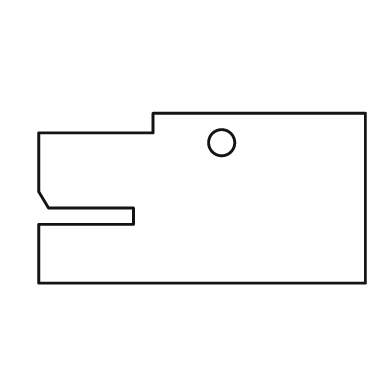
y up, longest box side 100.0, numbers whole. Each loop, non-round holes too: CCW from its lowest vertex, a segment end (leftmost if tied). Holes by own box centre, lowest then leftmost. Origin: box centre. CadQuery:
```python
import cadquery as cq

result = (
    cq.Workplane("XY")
    .moveTo(-50.0, -26.0)
    .lineTo(50.0, -26.0)
    .lineTo(50.0, 26.0)
    .lineTo(-15.0, 26.0)
    .lineTo(-15.0, 20.0)
    .lineTo(-50.0, 20.0)
    .lineTo(-50.0, 2.0)
    .lineTo(-47.0, -3.0)
    .lineTo(-21.0, -3.0)
    .lineTo(-21.0, -8.0)
    .lineTo(-50.0, -8.0)
    .close()
    .moveTo(6.0, 17.0)
    .circle(4.0)
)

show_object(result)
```